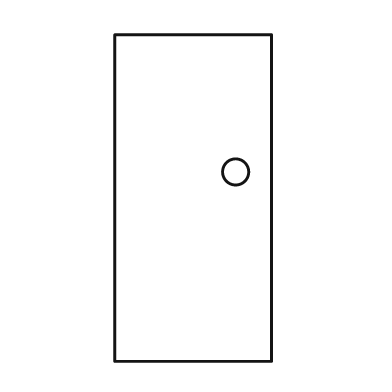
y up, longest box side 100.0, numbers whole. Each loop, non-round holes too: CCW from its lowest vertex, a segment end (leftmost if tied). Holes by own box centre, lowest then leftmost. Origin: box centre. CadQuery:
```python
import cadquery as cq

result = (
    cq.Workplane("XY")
    .moveTo(-24.0, -50.0)
    .lineTo(24.0, -50.0)
    .lineTo(24.0, 50.0)
    .lineTo(-24.0, 50.0)
    .close()
    .moveTo(13.0, 8.0)
    .circle(4.0)
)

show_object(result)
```